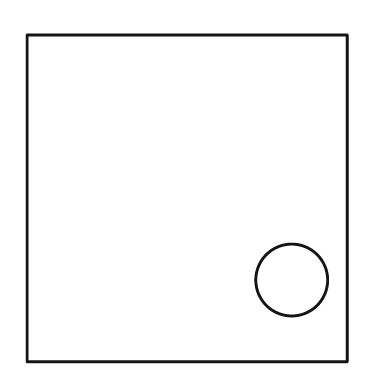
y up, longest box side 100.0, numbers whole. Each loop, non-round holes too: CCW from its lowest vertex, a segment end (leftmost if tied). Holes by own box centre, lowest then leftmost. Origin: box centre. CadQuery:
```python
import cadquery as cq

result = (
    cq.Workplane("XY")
    .moveTo(-49.0, -50.0)
    .lineTo(49.0, -50.0)
    .lineTo(49.0, 50.0)
    .lineTo(-49.0, 50.0)
    .close()
    .moveTo(32.0, -25.0)
    .circle(11.0)
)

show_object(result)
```